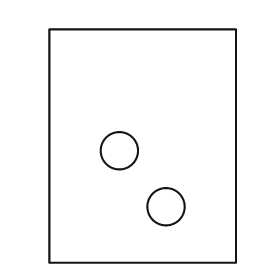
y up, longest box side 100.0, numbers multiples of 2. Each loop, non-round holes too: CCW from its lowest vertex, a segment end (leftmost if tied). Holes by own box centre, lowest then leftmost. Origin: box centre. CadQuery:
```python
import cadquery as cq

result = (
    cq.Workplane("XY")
    .moveTo(-40.0, -50.0)
    .lineTo(40.0, -50.0)
    .lineTo(40.0, 50.0)
    .lineTo(-40.0, 50.0)
    .close()
    .moveTo(10.0, -26.0)
    .circle(8.0)
    .moveTo(-10.0, -2.0)
    .circle(8.0)
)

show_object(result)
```